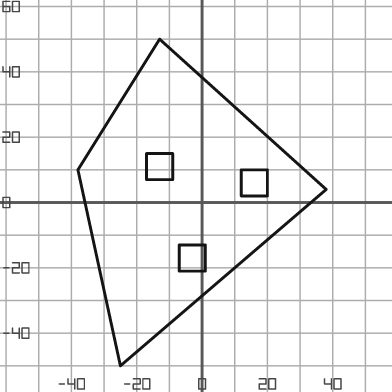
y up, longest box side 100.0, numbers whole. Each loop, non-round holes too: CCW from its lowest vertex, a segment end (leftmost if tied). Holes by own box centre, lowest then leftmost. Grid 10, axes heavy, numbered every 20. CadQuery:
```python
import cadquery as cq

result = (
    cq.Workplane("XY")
    .moveTo(-25.0, -50.0)
    .lineTo(38.0, 4.0)
    .lineTo(-13.0, 50.0)
    .lineTo(-38.0, 10.0)
    .close()
    .moveTo(-7.0, -21.0)
    .lineTo(1.0, -21.0)
    .lineTo(1.0, -13.0)
    .lineTo(-7.0, -13.0)
    .close()
    .moveTo(12.0, 2.0)
    .lineTo(20.0, 2.0)
    .lineTo(20.0, 10.0)
    .lineTo(12.0, 10.0)
    .close()
    .moveTo(-17.0, 7.0)
    .lineTo(-9.0, 7.0)
    .lineTo(-9.0, 15.0)
    .lineTo(-17.0, 15.0)
    .close()
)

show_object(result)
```